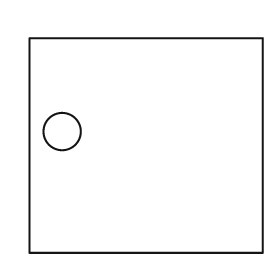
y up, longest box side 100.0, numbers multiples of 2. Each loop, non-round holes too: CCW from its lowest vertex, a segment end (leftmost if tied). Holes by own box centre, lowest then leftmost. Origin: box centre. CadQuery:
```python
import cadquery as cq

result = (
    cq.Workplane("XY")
    .moveTo(-50.0, -46.0)
    .lineTo(50.0, -46.0)
    .lineTo(50.0, 46.0)
    .lineTo(-50.0, 46.0)
    .close()
    .moveTo(-36.0, 6.0)
    .circle(8.0)
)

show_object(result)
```